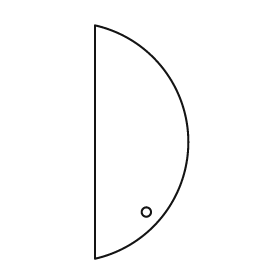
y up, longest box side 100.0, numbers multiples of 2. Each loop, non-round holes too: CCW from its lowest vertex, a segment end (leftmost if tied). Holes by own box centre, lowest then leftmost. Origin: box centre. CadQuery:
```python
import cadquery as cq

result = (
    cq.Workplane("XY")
    .moveTo(-20.0, -50.0)
    .threePointArc((20.0, 0.0), (-20.0, 50.0))
    .close()
    .moveTo(2.0, -30.0)
    .circle(2.0)
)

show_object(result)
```